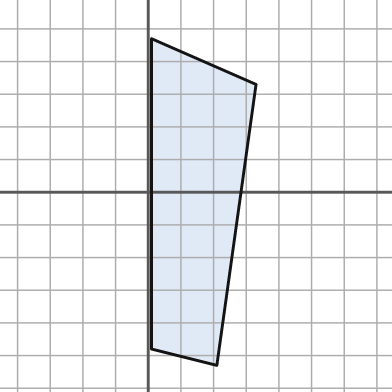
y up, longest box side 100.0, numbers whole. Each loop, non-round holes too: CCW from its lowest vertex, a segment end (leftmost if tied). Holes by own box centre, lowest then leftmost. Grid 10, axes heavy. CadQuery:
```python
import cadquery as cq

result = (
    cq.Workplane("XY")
    .moveTo(21.0, -53.0)
    .lineTo(33.0, 33.0)
    .lineTo(1.0, 47.0)
    .lineTo(1.0, -48.0)
    .close()
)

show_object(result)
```